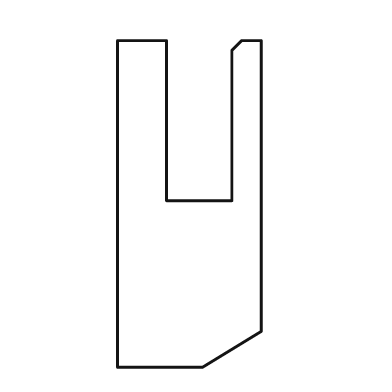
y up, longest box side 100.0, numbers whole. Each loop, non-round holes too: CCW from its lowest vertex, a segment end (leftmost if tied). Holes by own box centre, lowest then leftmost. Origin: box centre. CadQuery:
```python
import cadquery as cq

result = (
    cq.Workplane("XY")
    .moveTo(-22.0, -50.0)
    .lineTo(4.0, -50.0)
    .lineTo(22.0, -39.0)
    .lineTo(22.0, 50.0)
    .lineTo(16.0, 50.0)
    .lineTo(13.0, 47.0)
    .lineTo(13.0, 1.0)
    .lineTo(-7.0, 1.0)
    .lineTo(-7.0, 50.0)
    .lineTo(-22.0, 50.0)
    .close()
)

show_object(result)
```